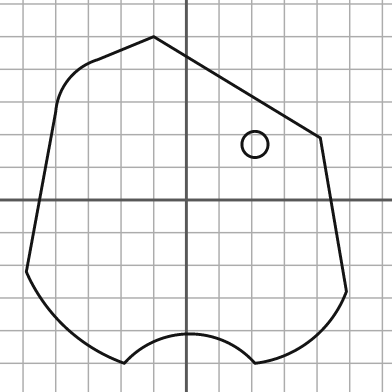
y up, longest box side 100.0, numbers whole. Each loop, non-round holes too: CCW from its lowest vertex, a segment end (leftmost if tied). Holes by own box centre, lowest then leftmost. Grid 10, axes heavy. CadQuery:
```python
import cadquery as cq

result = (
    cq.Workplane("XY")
    .moveTo(-19.0, -50.0)
    .threePointArc((1.0, -41.0), (21.0, -50.0))
    .threePointArc((38.0, -43.0), (49.0, -28.0))
    .lineTo(41.0, 19.0)
    .lineTo(-10.0, 50.0)
    .lineTo(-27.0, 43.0)
    .threePointArc((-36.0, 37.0), (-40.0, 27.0))
    .lineTo(-49.0, -22.0)
    .threePointArc((-37.0, -39.0), (-19.0, -50.0))
    .close()
    .moveTo(21.0, 17.0)
    .circle(4.0)
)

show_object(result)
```